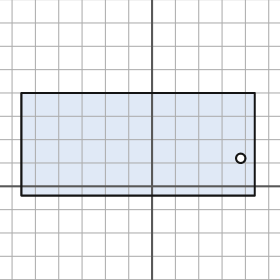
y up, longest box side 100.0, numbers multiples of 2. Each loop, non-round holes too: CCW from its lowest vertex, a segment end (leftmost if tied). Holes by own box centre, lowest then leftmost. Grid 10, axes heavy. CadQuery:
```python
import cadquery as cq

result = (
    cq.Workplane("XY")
    .moveTo(-56.0, -4.0)
    .lineTo(44.0, -4.0)
    .lineTo(44.0, 40.0)
    .lineTo(-56.0, 40.0)
    .close()
    .moveTo(38.0, 12.0)
    .circle(2.0)
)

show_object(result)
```